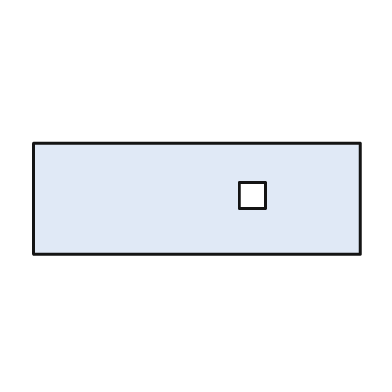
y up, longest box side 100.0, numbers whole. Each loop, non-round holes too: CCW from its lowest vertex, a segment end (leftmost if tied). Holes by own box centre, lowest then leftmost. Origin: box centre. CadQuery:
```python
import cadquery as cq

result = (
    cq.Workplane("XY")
    .moveTo(-50.0, -17.0)
    .lineTo(50.0, -17.0)
    .lineTo(50.0, 17.0)
    .lineTo(-50.0, 17.0)
    .close()
    .moveTo(13.0, -3.0)
    .lineTo(21.0, -3.0)
    .lineTo(21.0, 5.0)
    .lineTo(13.0, 5.0)
    .close()
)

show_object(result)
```